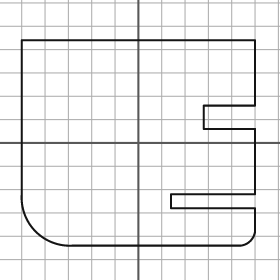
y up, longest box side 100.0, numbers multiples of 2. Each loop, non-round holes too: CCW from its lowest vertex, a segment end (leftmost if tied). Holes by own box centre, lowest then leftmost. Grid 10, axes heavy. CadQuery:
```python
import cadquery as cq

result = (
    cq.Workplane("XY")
    .moveTo(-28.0, -44.0)
    .lineTo(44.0, -44.0)
    .threePointArc((48.0, -42.0), (50.0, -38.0))
    .lineTo(50.0, -28.0)
    .lineTo(14.0, -28.0)
    .lineTo(14.0, -22.0)
    .lineTo(50.0, -22.0)
    .lineTo(50.0, 6.0)
    .lineTo(28.0, 6.0)
    .lineTo(28.0, 16.0)
    .lineTo(50.0, 16.0)
    .lineTo(50.0, 44.0)
    .lineTo(-50.0, 44.0)
    .lineTo(-50.0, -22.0)
    .threePointArc((-44.0, -38.0), (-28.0, -44.0))
    .close()
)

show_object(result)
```